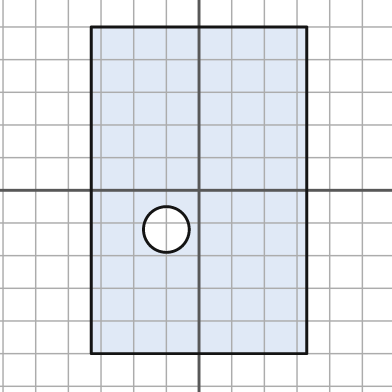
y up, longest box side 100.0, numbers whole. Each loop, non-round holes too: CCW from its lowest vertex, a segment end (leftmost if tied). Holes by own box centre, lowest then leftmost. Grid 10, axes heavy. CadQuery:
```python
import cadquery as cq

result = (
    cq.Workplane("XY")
    .moveTo(-33.0, -50.0)
    .lineTo(33.0, -50.0)
    .lineTo(33.0, 50.0)
    .lineTo(-33.0, 50.0)
    .close()
    .moveTo(-10.0, -12.0)
    .circle(7.0)
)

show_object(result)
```